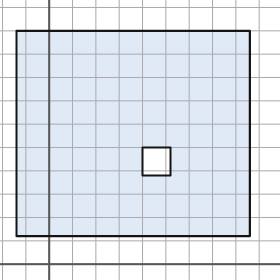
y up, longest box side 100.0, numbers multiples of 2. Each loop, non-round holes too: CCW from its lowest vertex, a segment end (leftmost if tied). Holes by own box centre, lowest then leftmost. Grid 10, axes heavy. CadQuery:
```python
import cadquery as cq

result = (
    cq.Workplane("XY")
    .moveTo(-14.0, 12.0)
    .lineTo(86.0, 12.0)
    .lineTo(86.0, 100.0)
    .lineTo(-14.0, 100.0)
    .close()
    .moveTo(40.0, 38.0)
    .lineTo(52.0, 38.0)
    .lineTo(52.0, 50.0)
    .lineTo(40.0, 50.0)
    .close()
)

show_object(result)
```